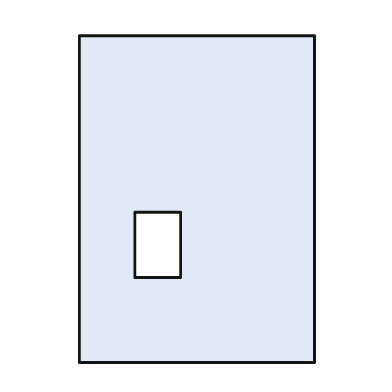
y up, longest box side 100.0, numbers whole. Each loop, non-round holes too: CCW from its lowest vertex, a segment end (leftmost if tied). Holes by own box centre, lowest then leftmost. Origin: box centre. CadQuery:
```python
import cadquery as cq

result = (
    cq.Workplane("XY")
    .moveTo(-36.0, -50.0)
    .lineTo(36.0, -50.0)
    .lineTo(36.0, 50.0)
    .lineTo(-36.0, 50.0)
    .close()
    .moveTo(-19.0, -24.0)
    .lineTo(-5.0, -24.0)
    .lineTo(-5.0, -4.0)
    .lineTo(-19.0, -4.0)
    .close()
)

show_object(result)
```